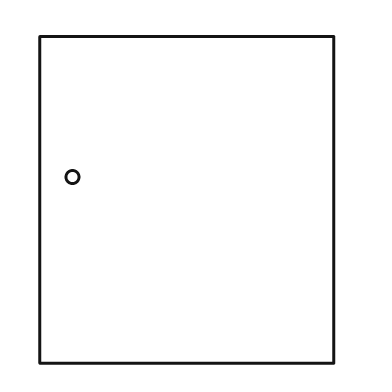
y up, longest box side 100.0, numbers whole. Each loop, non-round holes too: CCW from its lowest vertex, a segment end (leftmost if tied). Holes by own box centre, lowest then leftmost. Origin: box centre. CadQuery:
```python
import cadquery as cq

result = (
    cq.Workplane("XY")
    .moveTo(-45.0, -50.0)
    .lineTo(45.0, -50.0)
    .lineTo(45.0, 50.0)
    .lineTo(-45.0, 50.0)
    .close()
    .moveTo(-35.0, 7.0)
    .circle(2.0)
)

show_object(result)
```